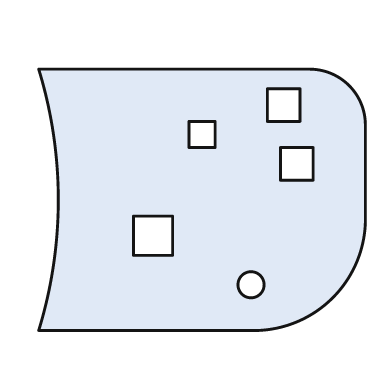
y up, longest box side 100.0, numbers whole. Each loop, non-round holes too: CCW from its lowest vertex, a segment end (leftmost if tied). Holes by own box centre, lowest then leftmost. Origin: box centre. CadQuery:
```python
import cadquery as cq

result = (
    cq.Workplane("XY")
    .moveTo(-50.0, -40.0)
    .lineTo(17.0, -40.0)
    .threePointArc((40.0, -30.0), (50.0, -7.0))
    .lineTo(50.0, 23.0)
    .threePointArc((45.0, 35.0), (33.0, 40.0))
    .lineTo(-50.0, 40.0)
    .threePointArc((-44.0, 0.0), (-50.0, -40.0))
    .close()
    .moveTo(15.0, -26.0)
    .circle(4.0)
    .moveTo(-21.0, -17.0)
    .lineTo(-9.0, -17.0)
    .lineTo(-9.0, -5.0)
    .lineTo(-21.0, -5.0)
    .close()
    .moveTo(24.0, 6.0)
    .lineTo(34.0, 6.0)
    .lineTo(34.0, 16.0)
    .lineTo(24.0, 16.0)
    .close()
    .moveTo(-4.0, 16.0)
    .lineTo(4.0, 16.0)
    .lineTo(4.0, 24.0)
    .lineTo(-4.0, 24.0)
    .close()
    .moveTo(20.0, 24.0)
    .lineTo(30.0, 24.0)
    .lineTo(30.0, 34.0)
    .lineTo(20.0, 34.0)
    .close()
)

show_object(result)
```